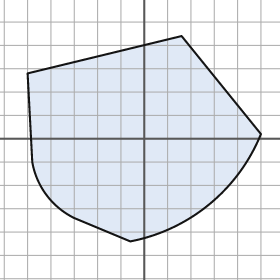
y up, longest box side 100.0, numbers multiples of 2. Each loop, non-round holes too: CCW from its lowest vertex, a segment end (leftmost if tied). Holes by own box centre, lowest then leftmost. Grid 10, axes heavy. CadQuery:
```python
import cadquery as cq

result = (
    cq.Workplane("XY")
    .moveTo(-6.0, -44.0)
    .threePointArc((28.0, -28.0), (50.0, 2.0))
    .lineTo(16.0, 44.0)
    .lineTo(-50.0, 28.0)
    .lineTo(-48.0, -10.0)
    .threePointArc((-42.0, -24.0), (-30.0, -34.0))
    .close()
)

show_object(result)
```